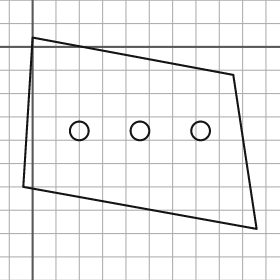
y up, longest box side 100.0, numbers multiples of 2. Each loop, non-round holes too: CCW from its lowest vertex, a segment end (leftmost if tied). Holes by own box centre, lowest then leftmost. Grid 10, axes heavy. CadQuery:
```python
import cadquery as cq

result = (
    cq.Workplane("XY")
    .moveTo(96.0, -78.0)
    .lineTo(86.0, -12.0)
    .lineTo(0.0, 4.0)
    .lineTo(-4.0, -60.0)
    .close()
    .moveTo(20.0, -36.0)
    .circle(4.0)
    .moveTo(46.0, -36.0)
    .circle(4.0)
    .moveTo(72.0, -36.0)
    .circle(4.0)
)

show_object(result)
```